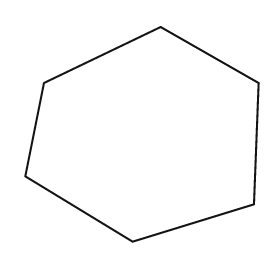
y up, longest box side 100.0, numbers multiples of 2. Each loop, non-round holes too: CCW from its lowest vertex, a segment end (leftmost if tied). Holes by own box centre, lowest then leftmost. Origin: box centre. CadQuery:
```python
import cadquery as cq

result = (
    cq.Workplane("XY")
    .moveTo(-4.0, -46.0)
    .lineTo(48.0, -30.0)
    .lineTo(50.0, 22.0)
    .lineTo(8.0, 46.0)
    .lineTo(-42.0, 22.0)
    .lineTo(-50.0, -18.0)
    .close()
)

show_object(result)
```